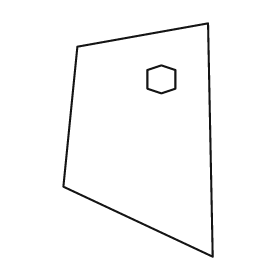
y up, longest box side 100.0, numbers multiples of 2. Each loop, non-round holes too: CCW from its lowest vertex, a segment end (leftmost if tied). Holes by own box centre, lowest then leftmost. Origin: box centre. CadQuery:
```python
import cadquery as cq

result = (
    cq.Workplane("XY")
    .moveTo(32.0, -50.0)
    .lineTo(30.0, 50.0)
    .lineTo(-26.0, 40.0)
    .lineTo(-32.0, -20.0)
    .close()
    .moveTo(10.0, 20.0)
    .lineTo(16.0, 22.0)
    .lineTo(16.0, 30.0)
    .lineTo(10.0, 32.0)
    .lineTo(4.0, 30.0)
    .lineTo(4.0, 22.0)
    .close()
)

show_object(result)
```